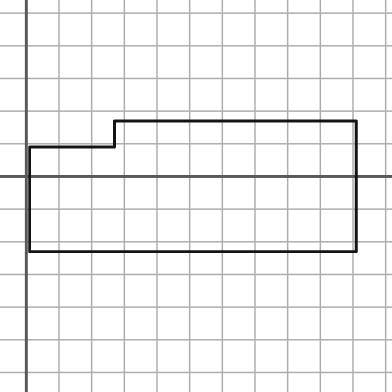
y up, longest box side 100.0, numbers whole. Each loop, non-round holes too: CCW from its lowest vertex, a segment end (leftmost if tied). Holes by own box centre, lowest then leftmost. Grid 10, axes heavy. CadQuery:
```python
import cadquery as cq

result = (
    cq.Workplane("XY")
    .moveTo(1.0, -23.0)
    .lineTo(101.0, -23.0)
    .lineTo(101.0, 17.0)
    .lineTo(27.0, 17.0)
    .lineTo(27.0, 9.0)
    .lineTo(1.0, 9.0)
    .close()
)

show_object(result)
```